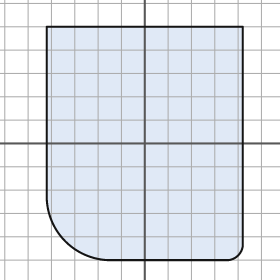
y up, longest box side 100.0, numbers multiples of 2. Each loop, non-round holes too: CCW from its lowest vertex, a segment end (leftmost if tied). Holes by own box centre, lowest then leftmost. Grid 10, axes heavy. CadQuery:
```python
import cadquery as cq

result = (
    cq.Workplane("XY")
    .moveTo(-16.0, -50.0)
    .lineTo(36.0, -50.0)
    .threePointArc((40.0, -48.0), (42.0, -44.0))
    .lineTo(42.0, 50.0)
    .lineTo(-42.0, 50.0)
    .lineTo(-42.0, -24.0)
    .threePointArc((-34.0, -42.0), (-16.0, -50.0))
    .close()
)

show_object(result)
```